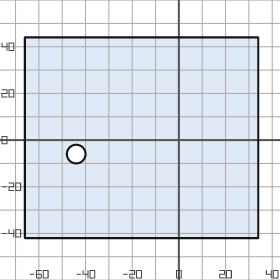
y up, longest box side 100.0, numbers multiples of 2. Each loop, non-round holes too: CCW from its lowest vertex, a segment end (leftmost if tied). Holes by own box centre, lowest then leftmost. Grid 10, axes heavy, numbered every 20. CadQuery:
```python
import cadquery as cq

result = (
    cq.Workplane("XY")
    .moveTo(-66.0, -42.0)
    .lineTo(34.0, -42.0)
    .lineTo(34.0, 44.0)
    .lineTo(-66.0, 44.0)
    .close()
    .moveTo(-44.0, -6.0)
    .circle(4.0)
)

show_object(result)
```